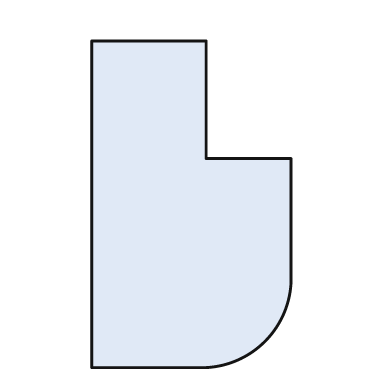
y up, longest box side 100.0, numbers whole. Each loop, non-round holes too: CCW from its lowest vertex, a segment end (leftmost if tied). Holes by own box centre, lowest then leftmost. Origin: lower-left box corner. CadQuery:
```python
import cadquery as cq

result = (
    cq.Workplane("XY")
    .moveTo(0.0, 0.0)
    .lineTo(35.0, 0.0)
    .threePointArc((53.0, 8.0), (61.0, 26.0))
    .lineTo(61.0, 64.0)
    .lineTo(35.0, 64.0)
    .lineTo(35.0, 100.0)
    .lineTo(0.0, 100.0)
    .close()
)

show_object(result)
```